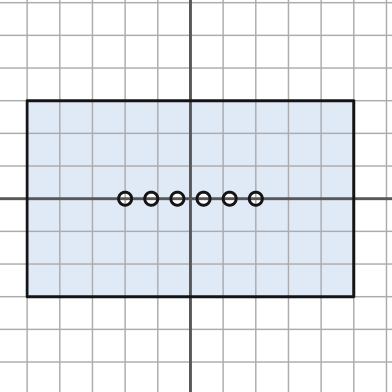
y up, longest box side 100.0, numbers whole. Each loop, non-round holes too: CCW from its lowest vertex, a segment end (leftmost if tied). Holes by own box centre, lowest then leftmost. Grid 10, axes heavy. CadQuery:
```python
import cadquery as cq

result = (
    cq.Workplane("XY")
    .moveTo(-50.0, -30.0)
    .lineTo(50.0, -30.0)
    .lineTo(50.0, 30.0)
    .lineTo(-50.0, 30.0)
    .close()
    .moveTo(-20.0, 0.0)
    .circle(2.0)
    .moveTo(-12.0, 0.0)
    .circle(2.0)
    .moveTo(-4.0, 0.0)
    .circle(2.0)
    .moveTo(4.0, 0.0)
    .circle(2.0)
    .moveTo(12.0, 0.0)
    .circle(2.0)
    .moveTo(20.0, 0.0)
    .circle(2.0)
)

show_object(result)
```